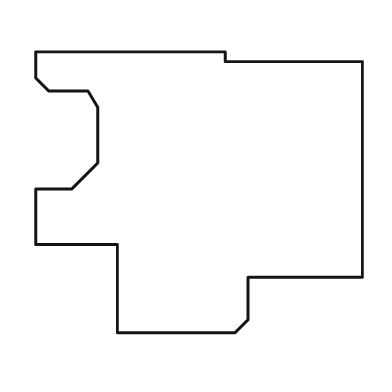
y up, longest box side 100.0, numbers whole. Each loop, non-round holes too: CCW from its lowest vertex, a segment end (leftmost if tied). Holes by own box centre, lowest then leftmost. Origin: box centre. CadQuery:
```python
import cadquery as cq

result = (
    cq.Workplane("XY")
    .moveTo(-25.0, -43.0)
    .lineTo(11.0, -43.0)
    .lineTo(15.0, -39.0)
    .lineTo(15.0, -26.0)
    .lineTo(50.0, -26.0)
    .lineTo(50.0, 40.0)
    .lineTo(8.0, 40.0)
    .lineTo(8.0, 43.0)
    .lineTo(-50.0, 43.0)
    .lineTo(-50.0, 35.0)
    .lineTo(-46.0, 31.0)
    .lineTo(-34.0, 31.0)
    .lineTo(-31.0, 26.0)
    .lineTo(-31.0, 9.0)
    .lineTo(-39.0, 1.0)
    .lineTo(-50.0, 1.0)
    .lineTo(-50.0, -16.0)
    .lineTo(-25.0, -16.0)
    .close()
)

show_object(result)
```